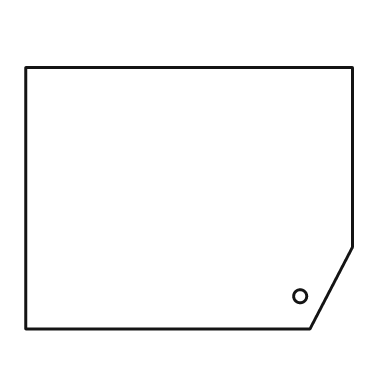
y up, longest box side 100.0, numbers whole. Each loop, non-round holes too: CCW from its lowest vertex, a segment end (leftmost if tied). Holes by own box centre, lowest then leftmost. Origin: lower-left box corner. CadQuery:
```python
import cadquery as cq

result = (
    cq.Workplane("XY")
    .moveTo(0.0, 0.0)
    .lineTo(87.0, 0.0)
    .lineTo(100.0, 25.0)
    .lineTo(100.0, 80.0)
    .lineTo(0.0, 80.0)
    .close()
    .moveTo(84.0, 10.0)
    .circle(2.0)
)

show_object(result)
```